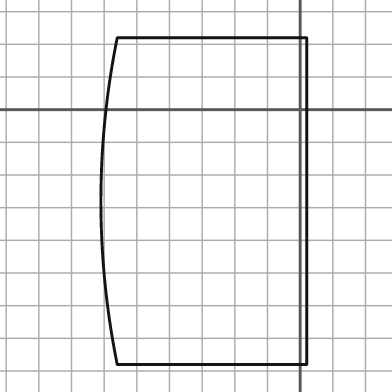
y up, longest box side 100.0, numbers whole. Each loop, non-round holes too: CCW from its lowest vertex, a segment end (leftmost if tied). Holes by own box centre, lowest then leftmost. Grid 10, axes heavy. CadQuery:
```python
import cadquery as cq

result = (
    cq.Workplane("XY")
    .moveTo(-56.0, -78.0)
    .lineTo(2.0, -78.0)
    .lineTo(2.0, 22.0)
    .lineTo(-56.0, 22.0)
    .threePointArc((-61.0, -28.0), (-56.0, -78.0))
    .close()
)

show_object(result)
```